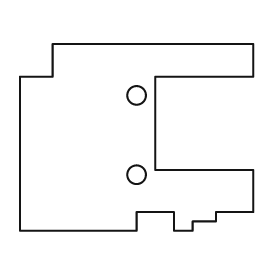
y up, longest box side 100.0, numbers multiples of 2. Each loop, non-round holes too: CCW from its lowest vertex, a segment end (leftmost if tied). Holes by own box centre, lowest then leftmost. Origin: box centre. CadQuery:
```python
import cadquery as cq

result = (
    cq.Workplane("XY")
    .moveTo(-50.0, -40.0)
    .lineTo(0.0, -40.0)
    .lineTo(0.0, -32.0)
    .lineTo(16.0, -32.0)
    .lineTo(16.0, -40.0)
    .lineTo(24.0, -40.0)
    .lineTo(24.0, -36.0)
    .lineTo(34.0, -36.0)
    .lineTo(34.0, -32.0)
    .lineTo(50.0, -32.0)
    .lineTo(50.0, -14.0)
    .lineTo(8.0, -14.0)
    .lineTo(8.0, 26.0)
    .lineTo(50.0, 26.0)
    .lineTo(50.0, 40.0)
    .lineTo(-36.0, 40.0)
    .lineTo(-36.0, 26.0)
    .lineTo(-50.0, 26.0)
    .close()
    .moveTo(0.0, -16.0)
    .circle(4.0)
    .moveTo(0.0, 18.0)
    .circle(4.0)
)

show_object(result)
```